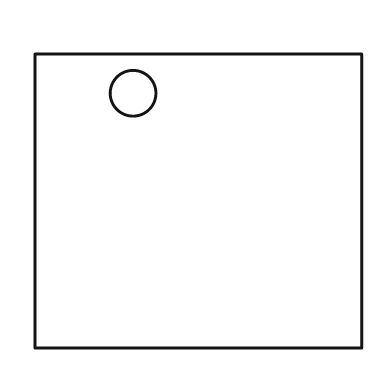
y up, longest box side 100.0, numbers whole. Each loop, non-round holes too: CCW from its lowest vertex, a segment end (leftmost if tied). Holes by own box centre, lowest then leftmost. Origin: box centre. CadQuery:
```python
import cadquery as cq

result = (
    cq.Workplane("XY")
    .moveTo(-50.0, -45.0)
    .lineTo(50.0, -45.0)
    .lineTo(50.0, 45.0)
    .lineTo(-50.0, 45.0)
    .close()
    .moveTo(-20.0, 33.0)
    .circle(7.0)
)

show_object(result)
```